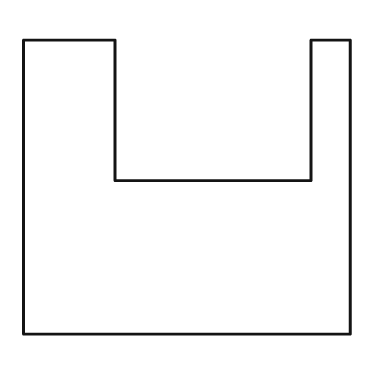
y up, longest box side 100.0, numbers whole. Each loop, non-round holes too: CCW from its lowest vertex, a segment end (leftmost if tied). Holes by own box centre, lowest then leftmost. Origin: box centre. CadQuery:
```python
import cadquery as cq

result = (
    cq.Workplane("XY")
    .moveTo(-50.0, -45.0)
    .lineTo(50.0, -45.0)
    .lineTo(50.0, 45.0)
    .lineTo(38.0, 45.0)
    .lineTo(38.0, 2.0)
    .lineTo(-22.0, 2.0)
    .lineTo(-22.0, 45.0)
    .lineTo(-50.0, 45.0)
    .close()
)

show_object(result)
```